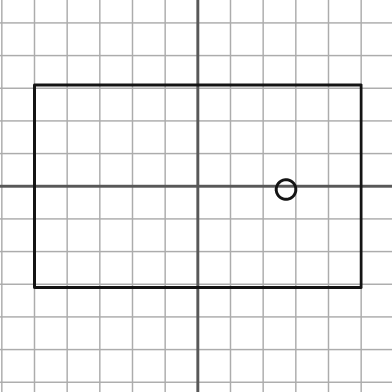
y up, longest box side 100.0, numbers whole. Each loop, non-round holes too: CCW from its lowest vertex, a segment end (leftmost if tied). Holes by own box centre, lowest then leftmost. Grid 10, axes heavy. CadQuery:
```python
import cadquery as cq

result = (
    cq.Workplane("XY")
    .moveTo(-50.0, -31.0)
    .lineTo(50.0, -31.0)
    .lineTo(50.0, 31.0)
    .lineTo(-50.0, 31.0)
    .close()
    .moveTo(27.0, -1.0)
    .circle(3.0)
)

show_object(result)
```